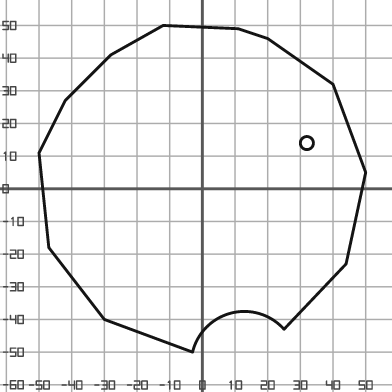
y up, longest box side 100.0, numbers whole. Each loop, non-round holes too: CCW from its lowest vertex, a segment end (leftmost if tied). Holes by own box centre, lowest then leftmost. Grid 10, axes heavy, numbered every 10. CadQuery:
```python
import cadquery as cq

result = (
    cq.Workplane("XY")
    .moveTo(-3.0, -50.0)
    .threePointArc((9.0, -38.0), (25.0, -43.0))
    .lineTo(44.0, -23.0)
    .lineTo(50.0, 5.0)
    .lineTo(40.0, 32.0)
    .lineTo(20.0, 46.0)
    .lineTo(11.0, 49.0)
    .lineTo(-12.0, 50.0)
    .lineTo(-28.0, 41.0)
    .lineTo(-42.0, 27.0)
    .lineTo(-50.0, 11.0)
    .lineTo(-47.0, -18.0)
    .lineTo(-30.0, -40.0)
    .close()
    .moveTo(32.0, 14.0)
    .circle(2.0)
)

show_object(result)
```